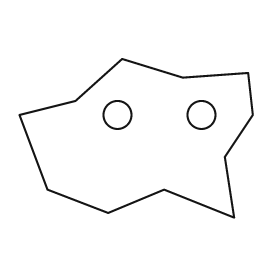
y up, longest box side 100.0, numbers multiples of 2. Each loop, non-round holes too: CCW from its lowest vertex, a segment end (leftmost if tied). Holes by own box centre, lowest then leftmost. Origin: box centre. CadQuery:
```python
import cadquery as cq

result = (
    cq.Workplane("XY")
    .moveTo(42.0, -34.0)
    .lineTo(38.0, -8.0)
    .lineTo(50.0, 10.0)
    .lineTo(48.0, 28.0)
    .lineTo(20.0, 26.0)
    .lineTo(-6.0, 34.0)
    .lineTo(-26.0, 16.0)
    .lineTo(-50.0, 10.0)
    .lineTo(-38.0, -22.0)
    .lineTo(-12.0, -32.0)
    .lineTo(12.0, -22.0)
    .close()
    .moveTo(-8.0, 10.0)
    .circle(6.0)
    .moveTo(28.0, 10.0)
    .circle(6.0)
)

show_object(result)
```